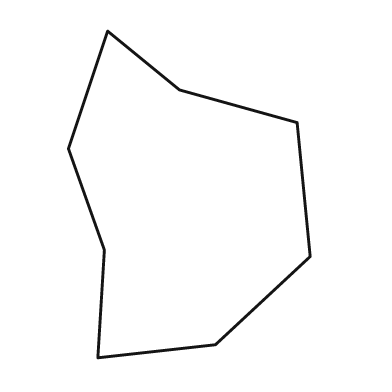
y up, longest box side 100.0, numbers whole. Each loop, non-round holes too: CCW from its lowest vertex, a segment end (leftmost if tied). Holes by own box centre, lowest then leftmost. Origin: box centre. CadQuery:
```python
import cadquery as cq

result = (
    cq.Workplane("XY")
    .moveTo(-28.0, -50.0)
    .lineTo(8.0, -46.0)
    .lineTo(37.0, -19.0)
    .lineTo(33.0, 22.0)
    .lineTo(-3.0, 32.0)
    .lineTo(-25.0, 50.0)
    .lineTo(-37.0, 14.0)
    .lineTo(-26.0, -17.0)
    .close()
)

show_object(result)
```